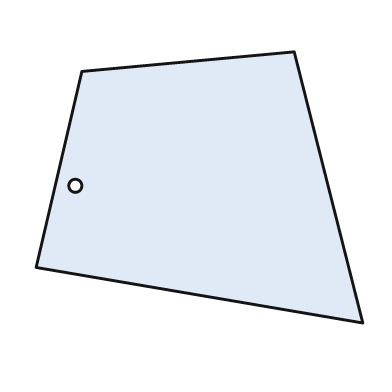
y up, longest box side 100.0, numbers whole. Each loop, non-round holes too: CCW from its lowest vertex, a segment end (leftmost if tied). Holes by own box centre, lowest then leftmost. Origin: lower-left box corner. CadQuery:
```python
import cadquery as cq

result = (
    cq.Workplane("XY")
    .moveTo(100.0, 0.0)
    .lineTo(79.0, 83.0)
    .lineTo(14.0, 77.0)
    .lineTo(0.0, 17.0)
    .close()
    .moveTo(12.0, 42.0)
    .circle(2.0)
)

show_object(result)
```